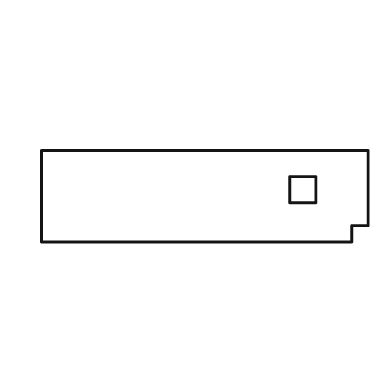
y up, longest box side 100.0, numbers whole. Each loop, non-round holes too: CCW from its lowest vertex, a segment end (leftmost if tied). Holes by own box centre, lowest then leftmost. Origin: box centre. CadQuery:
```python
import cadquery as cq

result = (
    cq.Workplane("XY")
    .moveTo(-50.0, -14.0)
    .lineTo(45.0, -14.0)
    .lineTo(45.0, -9.0)
    .lineTo(50.0, -9.0)
    .lineTo(50.0, 14.0)
    .lineTo(-50.0, 14.0)
    .close()
    .moveTo(26.0, -2.0)
    .lineTo(34.0, -2.0)
    .lineTo(34.0, 6.0)
    .lineTo(26.0, 6.0)
    .close()
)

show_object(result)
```